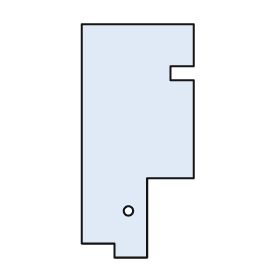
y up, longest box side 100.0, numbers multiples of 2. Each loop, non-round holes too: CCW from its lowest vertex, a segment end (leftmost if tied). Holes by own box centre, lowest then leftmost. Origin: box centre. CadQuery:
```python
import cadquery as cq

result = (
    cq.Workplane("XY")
    .moveTo(-10.0, -50.0)
    .lineTo(4.0, -50.0)
    .lineTo(4.0, -16.0)
    .lineTo(24.0, -16.0)
    .lineTo(24.0, 26.0)
    .lineTo(14.0, 26.0)
    .lineTo(14.0, 32.0)
    .lineTo(24.0, 32.0)
    .lineTo(24.0, 50.0)
    .lineTo(-24.0, 50.0)
    .lineTo(-24.0, -44.0)
    .lineTo(-10.0, -44.0)
    .close()
    .moveTo(-4.0, -30.0)
    .circle(2.0)
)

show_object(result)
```